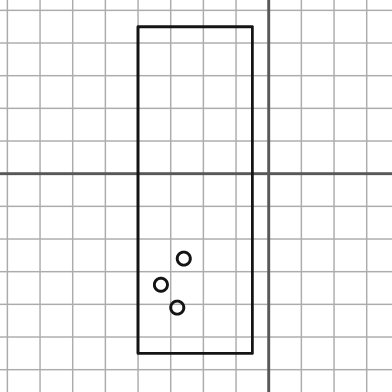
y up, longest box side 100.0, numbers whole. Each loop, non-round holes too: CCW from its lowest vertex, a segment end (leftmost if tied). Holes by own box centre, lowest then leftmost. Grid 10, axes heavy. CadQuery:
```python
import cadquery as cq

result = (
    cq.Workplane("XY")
    .moveTo(-40.0, -55.0)
    .lineTo(-5.0, -55.0)
    .lineTo(-5.0, 45.0)
    .lineTo(-40.0, 45.0)
    .close()
    .moveTo(-28.0, -41.0)
    .circle(2.0)
    .moveTo(-33.0, -34.0)
    .circle(2.0)
    .moveTo(-26.0, -26.0)
    .circle(2.0)
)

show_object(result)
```